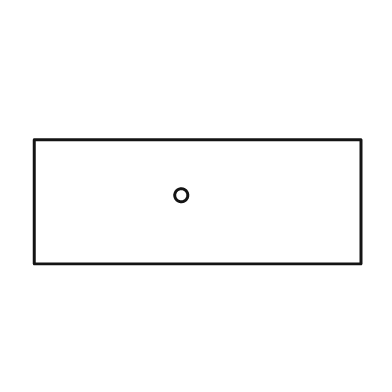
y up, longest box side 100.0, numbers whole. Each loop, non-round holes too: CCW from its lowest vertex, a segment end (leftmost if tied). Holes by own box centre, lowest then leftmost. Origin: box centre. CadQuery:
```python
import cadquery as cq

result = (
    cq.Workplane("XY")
    .moveTo(-50.0, -19.0)
    .lineTo(50.0, -19.0)
    .lineTo(50.0, 19.0)
    .lineTo(-50.0, 19.0)
    .close()
    .moveTo(-5.0, 2.0)
    .circle(2.0)
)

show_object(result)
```